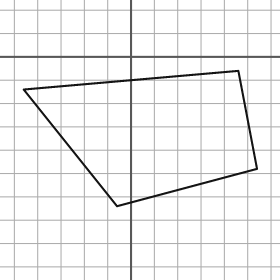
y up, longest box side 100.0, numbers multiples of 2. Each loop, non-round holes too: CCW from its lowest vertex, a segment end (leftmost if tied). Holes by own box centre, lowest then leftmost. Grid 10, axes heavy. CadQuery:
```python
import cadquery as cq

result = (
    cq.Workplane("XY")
    .moveTo(-6.0, -64.0)
    .lineTo(54.0, -48.0)
    .lineTo(46.0, -6.0)
    .lineTo(-46.0, -14.0)
    .close()
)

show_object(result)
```